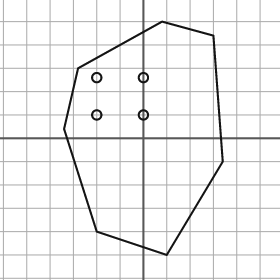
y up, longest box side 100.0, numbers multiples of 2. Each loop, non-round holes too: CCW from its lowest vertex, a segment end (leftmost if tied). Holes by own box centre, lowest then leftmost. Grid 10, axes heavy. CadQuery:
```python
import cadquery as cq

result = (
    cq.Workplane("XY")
    .moveTo(10.0, -50.0)
    .lineTo(34.0, -10.0)
    .lineTo(30.0, 44.0)
    .lineTo(8.0, 50.0)
    .lineTo(-28.0, 30.0)
    .lineTo(-34.0, 4.0)
    .lineTo(-20.0, -40.0)
    .close()
    .moveTo(-20.0, 10.0)
    .circle(2.0)
    .moveTo(0.0, 10.0)
    .circle(2.0)
    .moveTo(-20.0, 26.0)
    .circle(2.0)
    .moveTo(0.0, 26.0)
    .circle(2.0)
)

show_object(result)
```